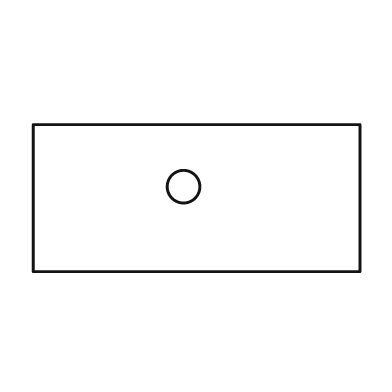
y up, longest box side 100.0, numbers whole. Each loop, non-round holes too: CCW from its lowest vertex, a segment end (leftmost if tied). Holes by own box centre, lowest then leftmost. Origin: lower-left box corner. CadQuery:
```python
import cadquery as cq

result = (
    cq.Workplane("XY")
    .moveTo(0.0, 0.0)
    .lineTo(100.0, 0.0)
    .lineTo(100.0, 45.0)
    .lineTo(0.0, 45.0)
    .close()
    .moveTo(46.0, 26.0)
    .circle(5.0)
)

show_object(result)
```